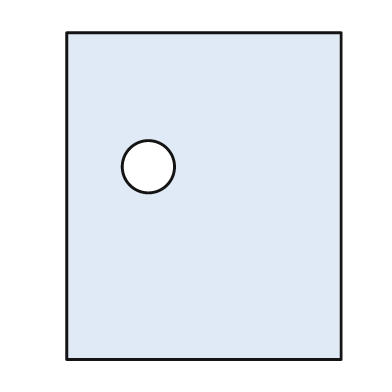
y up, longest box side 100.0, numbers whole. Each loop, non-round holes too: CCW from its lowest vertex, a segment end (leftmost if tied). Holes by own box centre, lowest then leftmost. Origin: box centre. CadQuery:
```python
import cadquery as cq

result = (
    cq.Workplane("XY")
    .moveTo(-42.0, -50.0)
    .lineTo(42.0, -50.0)
    .lineTo(42.0, 50.0)
    .lineTo(-42.0, 50.0)
    .close()
    .moveTo(-17.0, 9.0)
    .circle(8.0)
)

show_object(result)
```